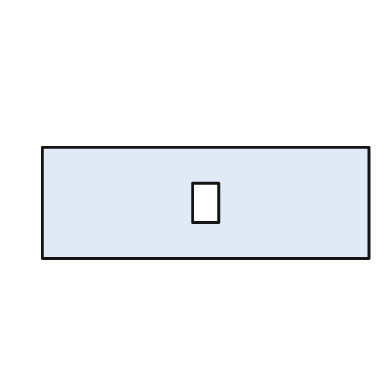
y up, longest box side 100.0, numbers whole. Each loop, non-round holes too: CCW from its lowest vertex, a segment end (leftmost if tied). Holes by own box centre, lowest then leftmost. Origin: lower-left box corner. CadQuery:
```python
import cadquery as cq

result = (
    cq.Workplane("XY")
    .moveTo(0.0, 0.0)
    .lineTo(100.0, 0.0)
    .lineTo(100.0, 34.0)
    .lineTo(0.0, 34.0)
    .close()
    .moveTo(46.0, 11.0)
    .lineTo(54.0, 11.0)
    .lineTo(54.0, 23.0)
    .lineTo(46.0, 23.0)
    .close()
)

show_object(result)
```